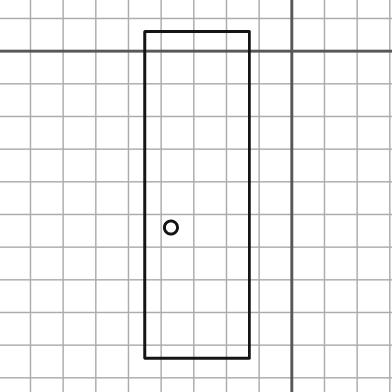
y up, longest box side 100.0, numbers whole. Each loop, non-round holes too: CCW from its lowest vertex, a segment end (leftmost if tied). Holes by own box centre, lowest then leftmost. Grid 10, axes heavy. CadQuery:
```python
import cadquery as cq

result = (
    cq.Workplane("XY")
    .moveTo(-45.0, -94.0)
    .lineTo(-13.0, -94.0)
    .lineTo(-13.0, 6.0)
    .lineTo(-45.0, 6.0)
    .close()
    .moveTo(-37.0, -54.0)
    .circle(2.0)
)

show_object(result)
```